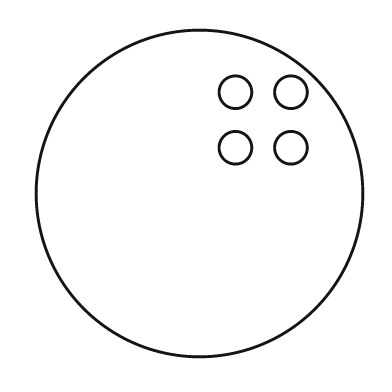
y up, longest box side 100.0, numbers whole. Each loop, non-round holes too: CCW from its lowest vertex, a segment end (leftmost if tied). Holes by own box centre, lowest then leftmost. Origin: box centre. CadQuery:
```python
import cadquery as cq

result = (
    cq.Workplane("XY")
    .moveTo(0.0, 0.0)
    .circle(50.0)
    .moveTo(11.0, 14.0)
    .circle(5.0)
    .moveTo(28.0, 14.0)
    .circle(5.0)
    .moveTo(11.0, 31.0)
    .circle(5.0)
    .moveTo(28.0, 31.0)
    .circle(5.0)
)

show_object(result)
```